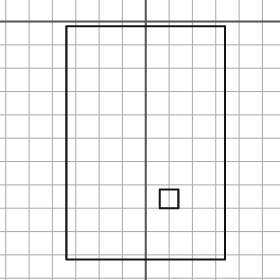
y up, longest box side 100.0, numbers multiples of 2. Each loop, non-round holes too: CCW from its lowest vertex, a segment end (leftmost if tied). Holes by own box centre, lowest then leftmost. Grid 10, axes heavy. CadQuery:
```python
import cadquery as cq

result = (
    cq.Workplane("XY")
    .moveTo(-34.0, -102.0)
    .lineTo(34.0, -102.0)
    .lineTo(34.0, -2.0)
    .lineTo(-34.0, -2.0)
    .close()
    .moveTo(6.0, -80.0)
    .lineTo(14.0, -80.0)
    .lineTo(14.0, -72.0)
    .lineTo(6.0, -72.0)
    .close()
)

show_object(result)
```